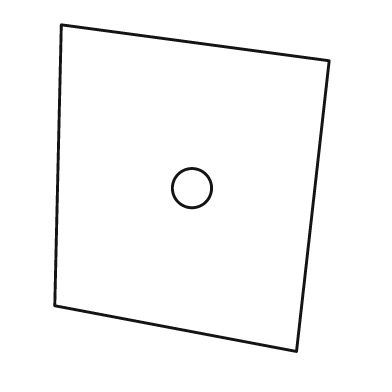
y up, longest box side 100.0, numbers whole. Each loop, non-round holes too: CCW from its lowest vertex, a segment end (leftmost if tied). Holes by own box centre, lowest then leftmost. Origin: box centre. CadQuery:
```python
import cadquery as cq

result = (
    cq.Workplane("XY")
    .moveTo(32.0, -50.0)
    .lineTo(42.0, 39.0)
    .lineTo(-40.0, 50.0)
    .lineTo(-42.0, -36.0)
    .close()
    .moveTo(0.0, 0.0)
    .circle(6.0)
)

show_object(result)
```